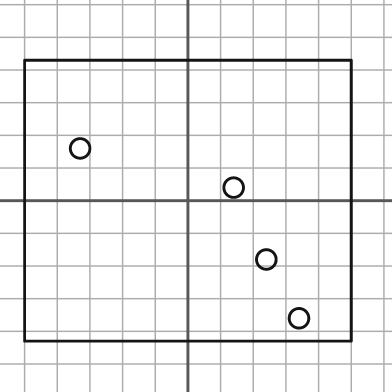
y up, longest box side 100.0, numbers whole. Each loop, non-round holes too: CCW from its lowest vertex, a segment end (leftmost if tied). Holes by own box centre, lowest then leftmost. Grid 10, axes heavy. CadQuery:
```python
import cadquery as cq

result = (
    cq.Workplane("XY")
    .moveTo(-50.0, -43.0)
    .lineTo(50.0, -43.0)
    .lineTo(50.0, 43.0)
    .lineTo(-50.0, 43.0)
    .close()
    .moveTo(34.0, -36.0)
    .circle(3.0)
    .moveTo(24.0, -18.0)
    .circle(3.0)
    .moveTo(14.0, 4.0)
    .circle(3.0)
    .moveTo(-33.0, 16.0)
    .circle(3.0)
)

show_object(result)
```